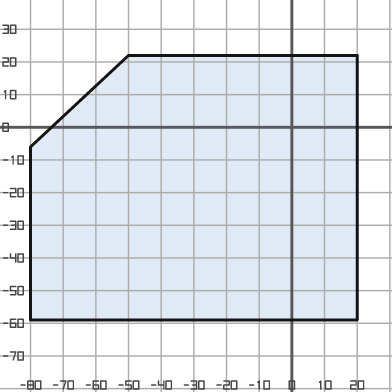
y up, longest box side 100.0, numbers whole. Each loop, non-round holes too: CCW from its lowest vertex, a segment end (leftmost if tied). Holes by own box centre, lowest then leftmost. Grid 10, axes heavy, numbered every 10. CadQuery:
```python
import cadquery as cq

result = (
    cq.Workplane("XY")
    .moveTo(-80.0, -59.0)
    .lineTo(20.0, -59.0)
    .lineTo(20.0, 22.0)
    .lineTo(-50.0, 22.0)
    .lineTo(-80.0, -6.0)
    .close()
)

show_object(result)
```